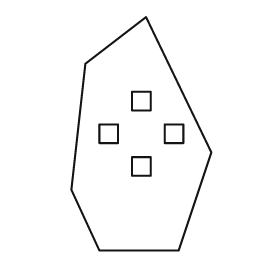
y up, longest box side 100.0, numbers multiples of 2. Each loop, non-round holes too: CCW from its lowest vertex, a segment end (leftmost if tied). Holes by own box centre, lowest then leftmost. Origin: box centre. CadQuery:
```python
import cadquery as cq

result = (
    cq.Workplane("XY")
    .moveTo(-18.0, -50.0)
    .lineTo(16.0, -50.0)
    .lineTo(30.0, -8.0)
    .lineTo(2.0, 50.0)
    .lineTo(-24.0, 30.0)
    .lineTo(-30.0, -24.0)
    .close()
    .moveTo(-4.0, -18.0)
    .lineTo(4.0, -18.0)
    .lineTo(4.0, -10.0)
    .lineTo(-4.0, -10.0)
    .close()
    .moveTo(-18.0, -4.0)
    .lineTo(-10.0, -4.0)
    .lineTo(-10.0, 4.0)
    .lineTo(-18.0, 4.0)
    .close()
    .moveTo(10.0, -4.0)
    .lineTo(18.0, -4.0)
    .lineTo(18.0, 4.0)
    .lineTo(10.0, 4.0)
    .close()
    .moveTo(-4.0, 10.0)
    .lineTo(4.0, 10.0)
    .lineTo(4.0, 18.0)
    .lineTo(-4.0, 18.0)
    .close()
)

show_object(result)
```